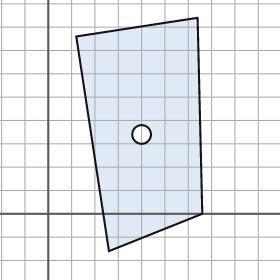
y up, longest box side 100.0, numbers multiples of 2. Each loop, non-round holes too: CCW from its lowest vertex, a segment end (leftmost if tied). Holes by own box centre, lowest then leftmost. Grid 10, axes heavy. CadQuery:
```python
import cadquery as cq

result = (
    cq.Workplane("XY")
    .moveTo(26.0, -16.0)
    .lineTo(66.0, 0.0)
    .lineTo(64.0, 84.0)
    .lineTo(12.0, 76.0)
    .close()
    .moveTo(40.0, 34.0)
    .circle(4.0)
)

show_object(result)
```